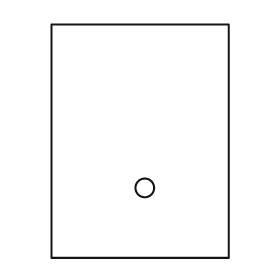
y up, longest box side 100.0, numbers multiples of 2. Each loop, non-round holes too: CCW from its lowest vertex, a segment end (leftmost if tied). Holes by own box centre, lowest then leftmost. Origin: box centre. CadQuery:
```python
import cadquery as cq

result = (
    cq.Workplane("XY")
    .moveTo(-38.0, -50.0)
    .lineTo(38.0, -50.0)
    .lineTo(38.0, 50.0)
    .lineTo(-38.0, 50.0)
    .close()
    .moveTo(2.0, -20.0)
    .circle(4.0)
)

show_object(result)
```